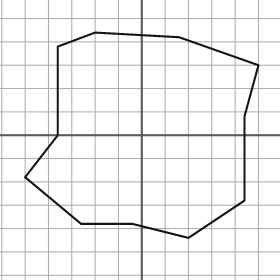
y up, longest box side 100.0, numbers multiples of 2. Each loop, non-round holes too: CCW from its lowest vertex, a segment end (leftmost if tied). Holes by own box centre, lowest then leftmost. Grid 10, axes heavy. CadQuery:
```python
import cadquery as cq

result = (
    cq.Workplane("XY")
    .moveTo(20.0, -44.0)
    .lineTo(44.0, -28.0)
    .lineTo(44.0, 8.0)
    .lineTo(50.0, 30.0)
    .lineTo(16.0, 42.0)
    .lineTo(-20.0, 44.0)
    .lineTo(-36.0, 38.0)
    .lineTo(-36.0, 0.0)
    .lineTo(-50.0, -18.0)
    .lineTo(-26.0, -38.0)
    .lineTo(-4.0, -38.0)
    .close()
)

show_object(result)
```